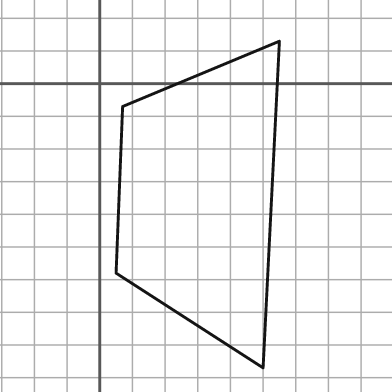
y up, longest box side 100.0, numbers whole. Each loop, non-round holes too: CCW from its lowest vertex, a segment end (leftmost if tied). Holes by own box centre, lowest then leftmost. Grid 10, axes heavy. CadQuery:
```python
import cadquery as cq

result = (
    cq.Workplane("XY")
    .moveTo(50.0, -87.0)
    .lineTo(55.0, 13.0)
    .lineTo(7.0, -7.0)
    .lineTo(5.0, -58.0)
    .close()
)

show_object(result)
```